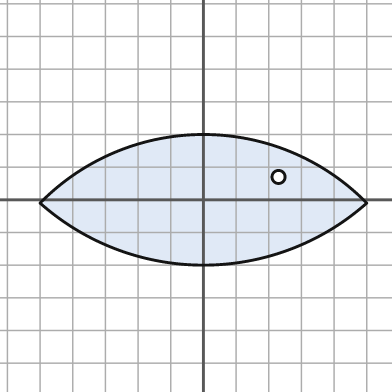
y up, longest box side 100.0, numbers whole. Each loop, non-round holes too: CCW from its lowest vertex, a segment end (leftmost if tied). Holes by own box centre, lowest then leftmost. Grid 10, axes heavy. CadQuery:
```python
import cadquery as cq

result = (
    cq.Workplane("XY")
    .moveTo(-50.0, -1.0)
    .threePointArc((0.0, -20.0), (50.0, -1.0))
    .threePointArc((0.0, 20.0), (-50.0, -1.0))
    .close()
    .moveTo(23.0, 7.0)
    .circle(2.0)
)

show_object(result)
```